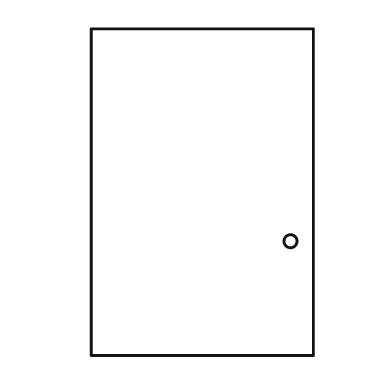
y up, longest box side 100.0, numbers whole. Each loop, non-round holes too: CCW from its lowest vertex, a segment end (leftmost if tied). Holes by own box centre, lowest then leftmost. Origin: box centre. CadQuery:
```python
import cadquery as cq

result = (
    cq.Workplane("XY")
    .moveTo(-34.0, -50.0)
    .lineTo(34.0, -50.0)
    .lineTo(34.0, 50.0)
    .lineTo(-34.0, 50.0)
    .close()
    .moveTo(27.0, -15.0)
    .circle(2.0)
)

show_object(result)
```